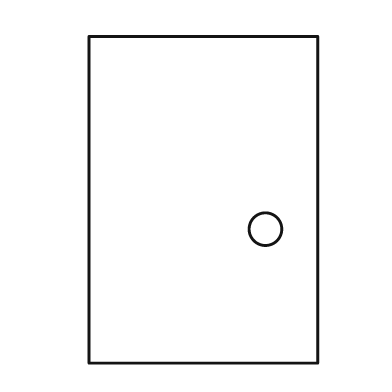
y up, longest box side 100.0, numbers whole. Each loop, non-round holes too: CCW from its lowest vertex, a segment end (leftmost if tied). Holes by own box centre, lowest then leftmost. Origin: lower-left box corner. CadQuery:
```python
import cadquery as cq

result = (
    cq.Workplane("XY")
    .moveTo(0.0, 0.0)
    .lineTo(70.0, 0.0)
    .lineTo(70.0, 100.0)
    .lineTo(0.0, 100.0)
    .close()
    .moveTo(54.0, 41.0)
    .circle(5.0)
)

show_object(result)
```